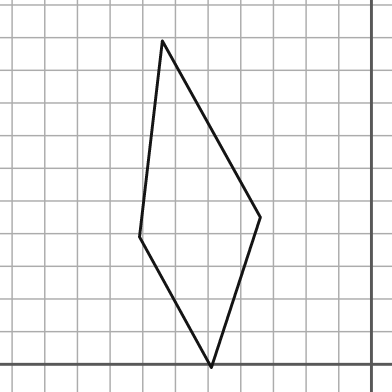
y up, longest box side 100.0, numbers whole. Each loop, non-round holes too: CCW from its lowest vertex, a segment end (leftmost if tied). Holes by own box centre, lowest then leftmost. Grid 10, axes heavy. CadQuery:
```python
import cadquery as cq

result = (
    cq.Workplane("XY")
    .moveTo(-49.0, -1.0)
    .lineTo(-34.0, 45.0)
    .lineTo(-64.0, 99.0)
    .lineTo(-71.0, 39.0)
    .close()
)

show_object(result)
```